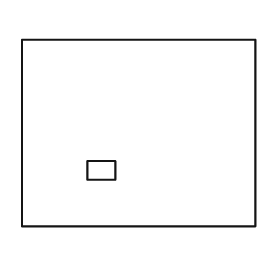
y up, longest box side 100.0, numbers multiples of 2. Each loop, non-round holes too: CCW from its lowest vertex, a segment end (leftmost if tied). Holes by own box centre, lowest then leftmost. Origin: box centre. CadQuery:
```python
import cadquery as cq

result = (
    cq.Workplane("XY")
    .moveTo(-50.0, -40.0)
    .lineTo(50.0, -40.0)
    .lineTo(50.0, 40.0)
    .lineTo(-50.0, 40.0)
    .close()
    .moveTo(-22.0, -20.0)
    .lineTo(-10.0, -20.0)
    .lineTo(-10.0, -12.0)
    .lineTo(-22.0, -12.0)
    .close()
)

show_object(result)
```